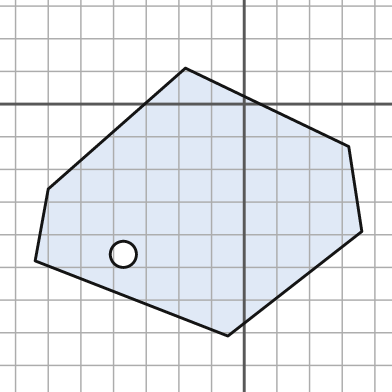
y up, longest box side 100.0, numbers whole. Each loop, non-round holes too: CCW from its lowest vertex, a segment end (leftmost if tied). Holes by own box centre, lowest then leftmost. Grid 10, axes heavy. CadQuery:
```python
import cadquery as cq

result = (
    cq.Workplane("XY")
    .moveTo(-5.0, -71.0)
    .lineTo(36.0, -39.0)
    .lineTo(32.0, -13.0)
    .lineTo(-18.0, 11.0)
    .lineTo(-60.0, -26.0)
    .lineTo(-64.0, -48.0)
    .close()
    .moveTo(-37.0, -46.0)
    .circle(4.0)
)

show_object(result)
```